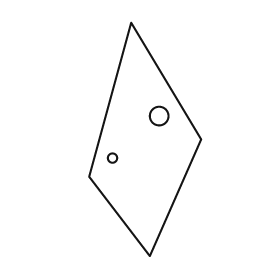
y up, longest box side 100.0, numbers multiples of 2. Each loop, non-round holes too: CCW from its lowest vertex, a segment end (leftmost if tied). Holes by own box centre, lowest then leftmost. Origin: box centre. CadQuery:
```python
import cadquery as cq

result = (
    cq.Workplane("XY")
    .moveTo(2.0, -50.0)
    .lineTo(24.0, 0.0)
    .lineTo(-6.0, 50.0)
    .lineTo(-24.0, -16.0)
    .close()
    .moveTo(-14.0, -8.0)
    .circle(2.0)
    .moveTo(6.0, 10.0)
    .circle(4.0)
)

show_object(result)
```